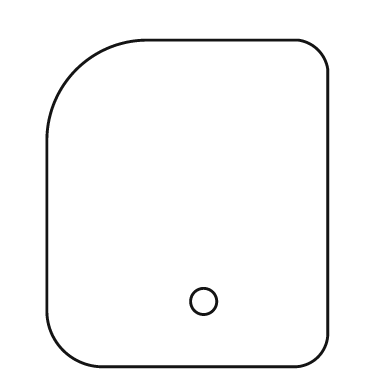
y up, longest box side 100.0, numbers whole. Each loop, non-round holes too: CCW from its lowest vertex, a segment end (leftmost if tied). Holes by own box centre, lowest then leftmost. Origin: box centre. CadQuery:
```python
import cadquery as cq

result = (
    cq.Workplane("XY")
    .moveTo(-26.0, -50.0)
    .lineTo(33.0, -50.0)
    .threePointArc((40.0, -47.0), (43.0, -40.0))
    .lineTo(43.0, 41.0)
    .threePointArc((40.0, 47.0), (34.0, 50.0))
    .lineTo(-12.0, 50.0)
    .threePointArc((-34.0, 41.0), (-43.0, 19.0))
    .lineTo(-43.0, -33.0)
    .threePointArc((-38.0, -45.0), (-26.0, -50.0))
    .close()
    .moveTo(5.0, -30.0)
    .circle(4.0)
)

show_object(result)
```